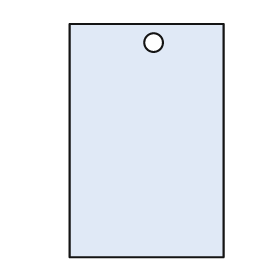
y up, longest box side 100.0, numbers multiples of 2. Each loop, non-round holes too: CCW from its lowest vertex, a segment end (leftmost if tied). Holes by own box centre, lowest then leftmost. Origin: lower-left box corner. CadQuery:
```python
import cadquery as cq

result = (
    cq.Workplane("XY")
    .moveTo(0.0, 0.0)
    .lineTo(66.0, 0.0)
    .lineTo(66.0, 100.0)
    .lineTo(0.0, 100.0)
    .close()
    .moveTo(36.0, 92.0)
    .circle(4.0)
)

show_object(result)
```